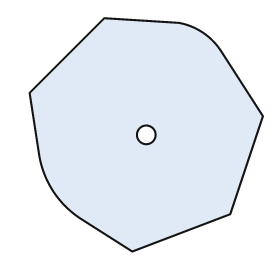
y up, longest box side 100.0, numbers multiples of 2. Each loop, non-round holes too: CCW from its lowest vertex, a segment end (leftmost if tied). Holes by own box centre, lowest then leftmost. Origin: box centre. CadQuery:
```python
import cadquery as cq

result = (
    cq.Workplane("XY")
    .moveTo(-6.0, -50.0)
    .lineTo(36.0, -34.0)
    .lineTo(50.0, 8.0)
    .lineTo(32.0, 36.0)
    .threePointArc((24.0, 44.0), (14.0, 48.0))
    .lineTo(-18.0, 50.0)
    .lineTo(-50.0, 18.0)
    .lineTo(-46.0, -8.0)
    .threePointArc((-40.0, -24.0), (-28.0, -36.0))
    .close()
    .moveTo(0.0, 0.0)
    .circle(4.0)
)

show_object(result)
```